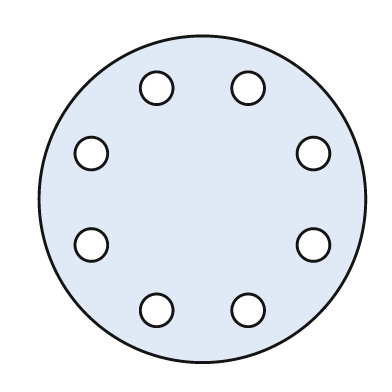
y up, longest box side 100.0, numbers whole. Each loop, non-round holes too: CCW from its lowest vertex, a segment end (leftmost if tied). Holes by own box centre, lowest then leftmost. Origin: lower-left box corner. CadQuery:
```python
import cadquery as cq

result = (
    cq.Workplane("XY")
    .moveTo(50.0, 50.0)
    .circle(50.0)
    .moveTo(36.0, 16.0)
    .circle(5.0)
    .moveTo(64.0, 16.0)
    .circle(5.0)
    .moveTo(16.0, 36.0)
    .circle(5.0)
    .moveTo(84.0, 36.0)
    .circle(5.0)
    .moveTo(16.0, 64.0)
    .circle(5.0)
    .moveTo(84.0, 64.0)
    .circle(5.0)
    .moveTo(36.0, 84.0)
    .circle(5.0)
    .moveTo(64.0, 84.0)
    .circle(5.0)
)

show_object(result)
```